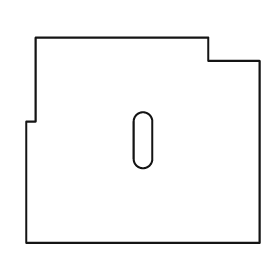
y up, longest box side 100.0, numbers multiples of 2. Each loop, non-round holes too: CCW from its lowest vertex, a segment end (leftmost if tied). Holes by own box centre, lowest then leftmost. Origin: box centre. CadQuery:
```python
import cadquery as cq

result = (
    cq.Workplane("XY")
    .moveTo(-50.0, -44.0)
    .lineTo(50.0, -44.0)
    .lineTo(50.0, 34.0)
    .lineTo(28.0, 34.0)
    .lineTo(28.0, 44.0)
    .lineTo(-46.0, 44.0)
    .lineTo(-46.0, 8.0)
    .lineTo(-50.0, 8.0)
    .close()
    .moveTo(-4.0, -8.0)
    .threePointArc((0.0, -12.0), (4.0, -8.0))
    .lineTo(4.0, 8.0)
    .threePointArc((0.0, 12.0), (-4.0, 8.0))
    .close()
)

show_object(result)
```